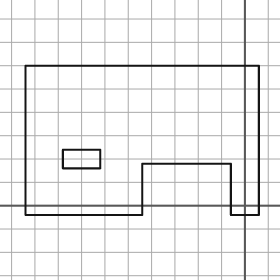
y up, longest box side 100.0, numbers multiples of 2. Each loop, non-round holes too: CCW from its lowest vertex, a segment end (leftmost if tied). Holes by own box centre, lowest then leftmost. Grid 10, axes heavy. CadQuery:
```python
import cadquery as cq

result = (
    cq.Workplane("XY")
    .moveTo(-94.0, -4.0)
    .lineTo(-44.0, -4.0)
    .lineTo(-44.0, 18.0)
    .lineTo(-6.0, 18.0)
    .lineTo(-6.0, -4.0)
    .lineTo(6.0, -4.0)
    .lineTo(6.0, 60.0)
    .lineTo(-94.0, 60.0)
    .close()
    .moveTo(-78.0, 16.0)
    .lineTo(-62.0, 16.0)
    .lineTo(-62.0, 24.0)
    .lineTo(-78.0, 24.0)
    .close()
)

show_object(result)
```